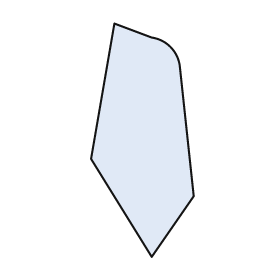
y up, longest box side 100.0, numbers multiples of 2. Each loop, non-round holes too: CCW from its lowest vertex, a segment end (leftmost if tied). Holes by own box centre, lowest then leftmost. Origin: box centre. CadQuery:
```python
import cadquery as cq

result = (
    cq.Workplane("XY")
    .moveTo(4.0, -50.0)
    .lineTo(22.0, -24.0)
    .lineTo(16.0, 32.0)
    .threePointArc((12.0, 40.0), (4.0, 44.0))
    .lineTo(-12.0, 50.0)
    .lineTo(-22.0, -8.0)
    .close()
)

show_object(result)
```